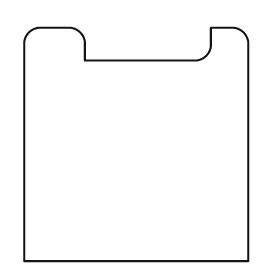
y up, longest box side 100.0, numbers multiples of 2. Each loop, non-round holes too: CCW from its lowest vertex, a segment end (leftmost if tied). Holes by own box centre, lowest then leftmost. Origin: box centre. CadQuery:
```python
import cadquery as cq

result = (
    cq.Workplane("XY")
    .moveTo(-48.0, -50.0)
    .lineTo(48.0, -50.0)
    .lineTo(48.0, 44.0)
    .threePointArc((46.0, 48.0), (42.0, 50.0))
    .lineTo(32.0, 50.0)
    .lineTo(32.0, 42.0)
    .threePointArc((30.0, 38.0), (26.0, 36.0))
    .lineTo(-22.0, 36.0)
    .lineTo(-22.0, 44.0)
    .threePointArc((-24.0, 48.0), (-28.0, 50.0))
    .lineTo(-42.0, 50.0)
    .threePointArc((-46.0, 48.0), (-48.0, 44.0))
    .close()
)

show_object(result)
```